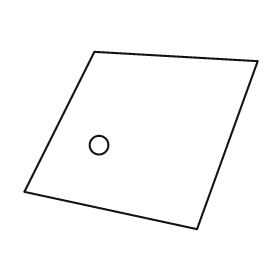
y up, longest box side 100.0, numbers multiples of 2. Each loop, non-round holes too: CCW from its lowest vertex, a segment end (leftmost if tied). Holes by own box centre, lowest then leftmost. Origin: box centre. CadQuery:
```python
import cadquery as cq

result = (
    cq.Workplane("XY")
    .moveTo(24.0, -38.0)
    .lineTo(50.0, 34.0)
    .lineTo(-20.0, 38.0)
    .lineTo(-50.0, -22.0)
    .close()
    .moveTo(-18.0, -2.0)
    .circle(4.0)
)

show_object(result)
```